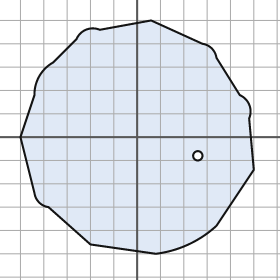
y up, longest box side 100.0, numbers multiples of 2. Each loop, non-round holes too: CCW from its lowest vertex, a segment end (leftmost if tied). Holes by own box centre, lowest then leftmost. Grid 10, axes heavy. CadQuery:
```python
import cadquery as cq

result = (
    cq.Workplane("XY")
    .moveTo(8.0, -50.0)
    .threePointArc((22.0, -46.0), (34.0, -38.0))
    .lineTo(50.0, -14.0)
    .lineTo(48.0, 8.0)
    .threePointArc((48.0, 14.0), (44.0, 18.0))
    .lineTo(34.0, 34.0)
    .threePointArc((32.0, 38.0), (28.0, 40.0))
    .lineTo(6.0, 50.0)
    .lineTo(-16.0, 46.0)
    .threePointArc((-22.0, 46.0), (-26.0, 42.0))
    .lineTo(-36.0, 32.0)
    .threePointArc((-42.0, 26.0), (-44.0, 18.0))
    .lineTo(-50.0, 0.0)
    .lineTo(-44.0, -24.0)
    .threePointArc((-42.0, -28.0), (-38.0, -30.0))
    .lineTo(-20.0, -46.0)
    .close()
    .moveTo(26.0, -8.0)
    .circle(2.0)
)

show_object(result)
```